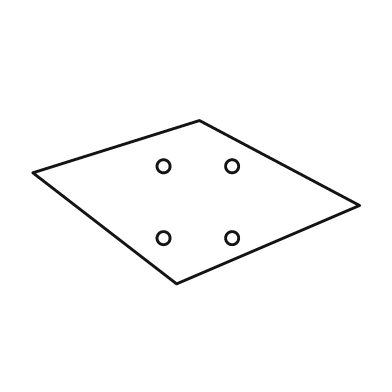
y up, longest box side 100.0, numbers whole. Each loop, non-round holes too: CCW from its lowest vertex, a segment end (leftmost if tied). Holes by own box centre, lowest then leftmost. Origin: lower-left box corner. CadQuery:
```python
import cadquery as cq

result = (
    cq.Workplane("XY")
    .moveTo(44.0, 0.0)
    .lineTo(100.0, 24.0)
    .lineTo(51.0, 50.0)
    .lineTo(0.0, 34.0)
    .close()
    .moveTo(40.0, 14.0)
    .circle(2.0)
    .moveTo(61.0, 14.0)
    .circle(2.0)
    .moveTo(40.0, 36.0)
    .circle(2.0)
    .moveTo(61.0, 36.0)
    .circle(2.0)
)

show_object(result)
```